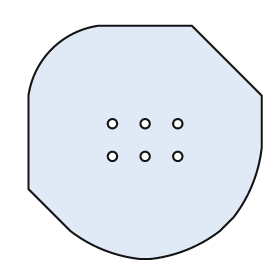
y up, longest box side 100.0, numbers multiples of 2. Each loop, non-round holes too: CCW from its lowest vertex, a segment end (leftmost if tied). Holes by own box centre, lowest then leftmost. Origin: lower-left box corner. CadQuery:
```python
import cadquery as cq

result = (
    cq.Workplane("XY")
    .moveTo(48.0, 0.0)
    .lineTo(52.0, 0.0)
    .threePointArc((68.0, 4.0), (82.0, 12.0))
    .lineTo(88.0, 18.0)
    .threePointArc((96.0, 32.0), (100.0, 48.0))
    .lineTo(100.0, 70.0)
    .lineTo(70.0, 100.0)
    .lineTo(30.0, 100.0)
    .threePointArc((10.0, 90.0), (0.0, 70.0))
    .lineTo(0.0, 30.0)
    .lineTo(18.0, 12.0)
    .threePointArc((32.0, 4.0), (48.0, 0.0))
    .close()
    .moveTo(36.0, 44.0)
    .circle(2.0)
    .moveTo(50.0, 44.0)
    .circle(2.0)
    .moveTo(64.0, 44.0)
    .circle(2.0)
    .moveTo(36.0, 58.0)
    .circle(2.0)
    .moveTo(50.0, 58.0)
    .circle(2.0)
    .moveTo(64.0, 58.0)
    .circle(2.0)
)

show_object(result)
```